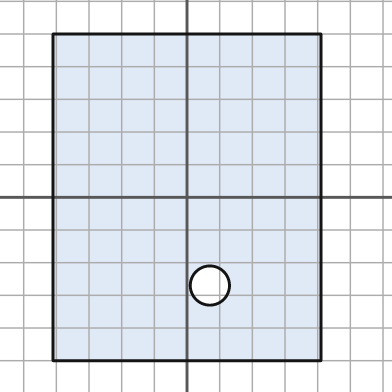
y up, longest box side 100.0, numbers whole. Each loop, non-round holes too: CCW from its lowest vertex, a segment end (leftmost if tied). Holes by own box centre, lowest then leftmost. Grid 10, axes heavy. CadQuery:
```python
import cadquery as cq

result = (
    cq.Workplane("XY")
    .moveTo(-41.0, -50.0)
    .lineTo(41.0, -50.0)
    .lineTo(41.0, 50.0)
    .lineTo(-41.0, 50.0)
    .close()
    .moveTo(7.0, -27.0)
    .circle(6.0)
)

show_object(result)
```